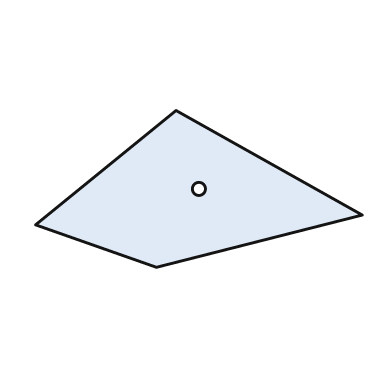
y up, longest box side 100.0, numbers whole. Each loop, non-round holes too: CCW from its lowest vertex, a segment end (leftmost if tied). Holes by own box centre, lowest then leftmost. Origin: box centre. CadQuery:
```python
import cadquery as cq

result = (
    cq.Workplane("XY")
    .moveTo(-13.0, -24.0)
    .lineTo(50.0, -8.0)
    .lineTo(-7.0, 24.0)
    .lineTo(-50.0, -11.0)
    .close()
    .moveTo(0.0, 0.0)
    .circle(2.0)
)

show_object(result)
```